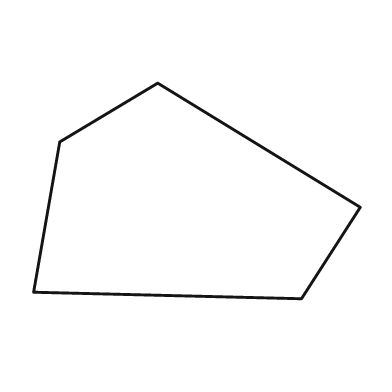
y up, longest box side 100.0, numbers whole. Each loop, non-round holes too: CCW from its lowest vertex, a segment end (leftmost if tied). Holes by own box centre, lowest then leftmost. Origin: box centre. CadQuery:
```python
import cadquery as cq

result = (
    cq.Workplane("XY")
    .moveTo(32.0, -33.0)
    .lineTo(50.0, -5.0)
    .lineTo(-12.0, 33.0)
    .lineTo(-42.0, 15.0)
    .lineTo(-50.0, -31.0)
    .close()
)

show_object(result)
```